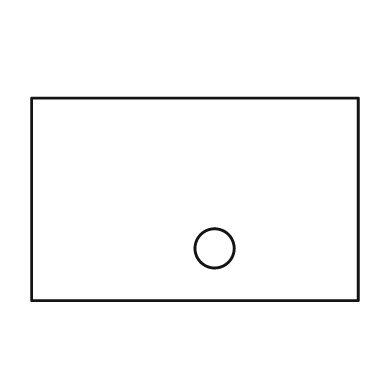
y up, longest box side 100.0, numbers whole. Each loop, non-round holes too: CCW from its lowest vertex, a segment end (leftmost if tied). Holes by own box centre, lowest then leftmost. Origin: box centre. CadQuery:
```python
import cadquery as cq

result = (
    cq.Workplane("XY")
    .moveTo(-50.0, -31.0)
    .lineTo(50.0, -31.0)
    .lineTo(50.0, 31.0)
    .lineTo(-50.0, 31.0)
    .close()
    .moveTo(6.0, -15.0)
    .circle(6.0)
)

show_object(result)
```